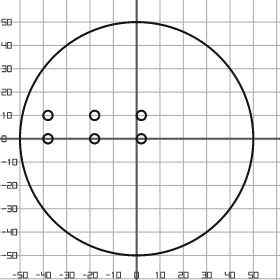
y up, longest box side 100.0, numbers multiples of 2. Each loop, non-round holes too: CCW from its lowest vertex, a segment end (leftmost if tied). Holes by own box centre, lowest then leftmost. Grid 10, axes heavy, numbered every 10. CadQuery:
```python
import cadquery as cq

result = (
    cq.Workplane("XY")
    .moveTo(0.0, 0.0)
    .circle(50.0)
    .moveTo(-38.0, 0.0)
    .circle(2.0)
    .moveTo(-18.0, 0.0)
    .circle(2.0)
    .moveTo(2.0, 0.0)
    .circle(2.0)
    .moveTo(-38.0, 10.0)
    .circle(2.0)
    .moveTo(-18.0, 10.0)
    .circle(2.0)
    .moveTo(2.0, 10.0)
    .circle(2.0)
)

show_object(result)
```